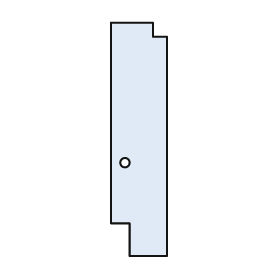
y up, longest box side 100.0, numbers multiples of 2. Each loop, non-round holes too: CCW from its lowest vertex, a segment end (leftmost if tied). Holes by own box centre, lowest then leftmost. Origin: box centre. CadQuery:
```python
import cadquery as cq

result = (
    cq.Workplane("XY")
    .moveTo(-4.0, -50.0)
    .lineTo(12.0, -50.0)
    .lineTo(12.0, 44.0)
    .lineTo(6.0, 44.0)
    .lineTo(6.0, 50.0)
    .lineTo(-12.0, 50.0)
    .lineTo(-12.0, -36.0)
    .lineTo(-4.0, -36.0)
    .close()
    .moveTo(-6.0, -10.0)
    .circle(2.0)
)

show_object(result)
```